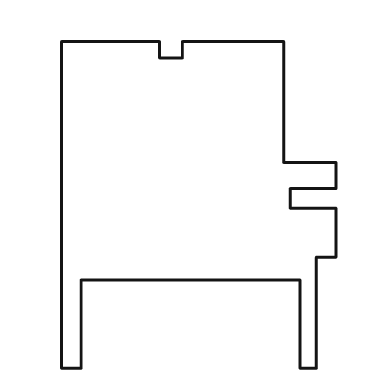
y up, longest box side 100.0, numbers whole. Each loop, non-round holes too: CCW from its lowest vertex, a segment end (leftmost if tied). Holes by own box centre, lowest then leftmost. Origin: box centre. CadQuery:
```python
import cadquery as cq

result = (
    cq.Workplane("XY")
    .moveTo(-42.0, -50.0)
    .lineTo(-36.0, -50.0)
    .lineTo(-36.0, -23.0)
    .lineTo(31.0, -23.0)
    .lineTo(31.0, -50.0)
    .lineTo(36.0, -50.0)
    .lineTo(36.0, -16.0)
    .lineTo(42.0, -16.0)
    .lineTo(42.0, -1.0)
    .lineTo(28.0, -1.0)
    .lineTo(28.0, 5.0)
    .lineTo(42.0, 5.0)
    .lineTo(42.0, 13.0)
    .lineTo(26.0, 13.0)
    .lineTo(26.0, 50.0)
    .lineTo(-5.0, 50.0)
    .lineTo(-5.0, 45.0)
    .lineTo(-12.0, 45.0)
    .lineTo(-12.0, 50.0)
    .lineTo(-42.0, 50.0)
    .close()
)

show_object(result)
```